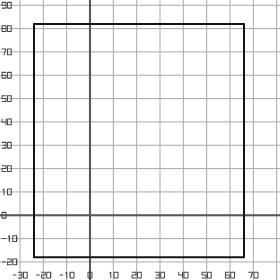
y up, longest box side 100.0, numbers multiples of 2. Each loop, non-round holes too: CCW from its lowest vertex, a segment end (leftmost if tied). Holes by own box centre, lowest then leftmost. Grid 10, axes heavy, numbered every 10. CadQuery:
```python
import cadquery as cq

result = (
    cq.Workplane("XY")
    .moveTo(-24.0, -18.0)
    .lineTo(66.0, -18.0)
    .lineTo(66.0, 82.0)
    .lineTo(-24.0, 82.0)
    .close()
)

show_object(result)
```